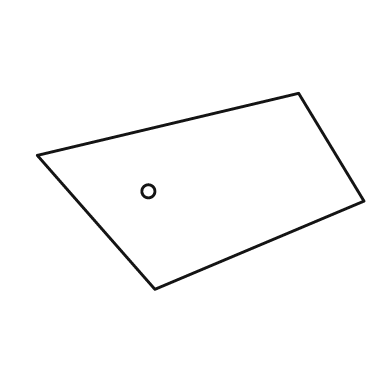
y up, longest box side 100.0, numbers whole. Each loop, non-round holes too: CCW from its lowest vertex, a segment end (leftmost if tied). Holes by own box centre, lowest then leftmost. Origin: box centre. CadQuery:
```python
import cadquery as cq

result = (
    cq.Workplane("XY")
    .moveTo(-14.0, -30.0)
    .lineTo(50.0, -3.0)
    .lineTo(30.0, 30.0)
    .lineTo(-50.0, 11.0)
    .close()
    .moveTo(-16.0, 0.0)
    .circle(2.0)
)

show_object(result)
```